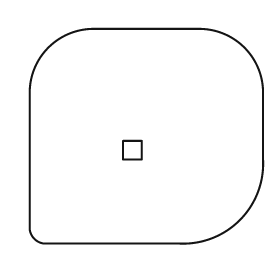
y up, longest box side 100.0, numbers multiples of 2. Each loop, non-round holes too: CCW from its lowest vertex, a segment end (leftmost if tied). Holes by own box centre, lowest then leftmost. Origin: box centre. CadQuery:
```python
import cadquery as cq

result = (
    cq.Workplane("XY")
    .moveTo(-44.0, -46.0)
    .lineTo(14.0, -46.0)
    .threePointArc((40.0, -36.0), (50.0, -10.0))
    .lineTo(50.0, 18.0)
    .threePointArc((42.0, 38.0), (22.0, 46.0))
    .lineTo(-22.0, 46.0)
    .threePointArc((-42.0, 38.0), (-50.0, 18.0))
    .lineTo(-50.0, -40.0)
    .threePointArc((-48.0, -44.0), (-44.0, -46.0))
    .close()
    .moveTo(-10.0, -10.0)
    .lineTo(-2.0, -10.0)
    .lineTo(-2.0, -2.0)
    .lineTo(-10.0, -2.0)
    .close()
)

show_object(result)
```